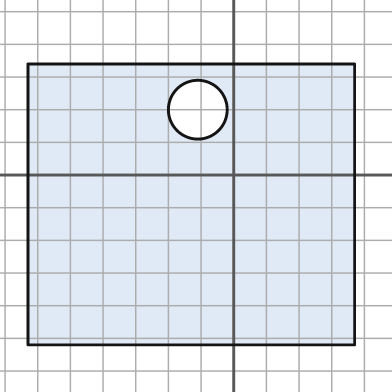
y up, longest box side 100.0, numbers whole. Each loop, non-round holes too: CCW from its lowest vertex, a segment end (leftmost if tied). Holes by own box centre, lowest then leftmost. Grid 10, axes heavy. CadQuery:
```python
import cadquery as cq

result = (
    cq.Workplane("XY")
    .moveTo(-63.0, -52.0)
    .lineTo(37.0, -52.0)
    .lineTo(37.0, 34.0)
    .lineTo(-63.0, 34.0)
    .close()
    .moveTo(-11.0, 20.0)
    .circle(9.0)
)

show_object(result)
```